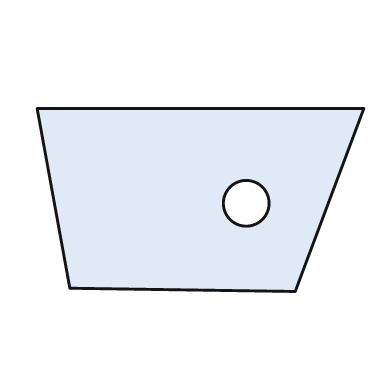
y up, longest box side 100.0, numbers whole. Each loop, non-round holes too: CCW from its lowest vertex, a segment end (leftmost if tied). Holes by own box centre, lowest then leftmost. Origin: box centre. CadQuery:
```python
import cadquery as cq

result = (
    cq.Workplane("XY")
    .moveTo(29.0, -28.0)
    .lineTo(50.0, 28.0)
    .lineTo(-50.0, 28.0)
    .lineTo(-40.0, -27.0)
    .close()
    .moveTo(14.0, -1.0)
    .circle(7.0)
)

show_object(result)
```